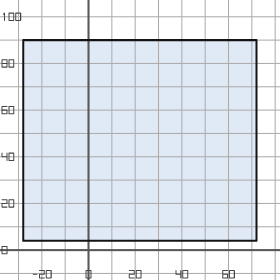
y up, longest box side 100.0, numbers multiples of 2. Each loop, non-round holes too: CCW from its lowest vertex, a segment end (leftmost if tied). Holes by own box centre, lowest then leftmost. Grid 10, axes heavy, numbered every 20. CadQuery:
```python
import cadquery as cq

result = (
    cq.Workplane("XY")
    .moveTo(-28.0, 4.0)
    .lineTo(72.0, 4.0)
    .lineTo(72.0, 90.0)
    .lineTo(-28.0, 90.0)
    .close()
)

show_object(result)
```